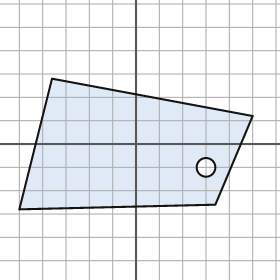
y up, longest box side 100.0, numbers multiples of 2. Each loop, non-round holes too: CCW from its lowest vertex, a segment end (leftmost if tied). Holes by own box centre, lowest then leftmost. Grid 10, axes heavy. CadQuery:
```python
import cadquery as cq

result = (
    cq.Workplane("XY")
    .moveTo(-50.0, -28.0)
    .lineTo(34.0, -26.0)
    .lineTo(50.0, 12.0)
    .lineTo(-36.0, 28.0)
    .close()
    .moveTo(30.0, -10.0)
    .circle(4.0)
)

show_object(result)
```